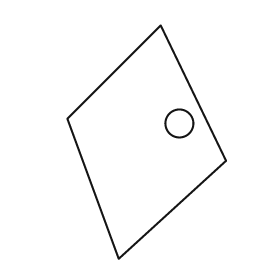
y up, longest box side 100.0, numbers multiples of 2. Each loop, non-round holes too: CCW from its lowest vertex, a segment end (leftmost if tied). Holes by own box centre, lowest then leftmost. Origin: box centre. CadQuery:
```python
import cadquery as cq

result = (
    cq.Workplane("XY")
    .moveTo(-12.0, -50.0)
    .lineTo(34.0, -8.0)
    .lineTo(6.0, 50.0)
    .lineTo(-34.0, 10.0)
    .close()
    .moveTo(14.0, 8.0)
    .circle(6.0)
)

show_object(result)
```